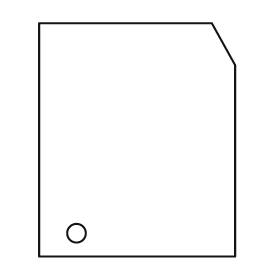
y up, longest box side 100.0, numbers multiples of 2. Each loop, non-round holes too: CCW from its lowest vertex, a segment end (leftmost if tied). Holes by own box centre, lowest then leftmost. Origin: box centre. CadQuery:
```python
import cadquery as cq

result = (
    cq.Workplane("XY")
    .moveTo(-42.0, -50.0)
    .lineTo(42.0, -50.0)
    .lineTo(42.0, 32.0)
    .lineTo(32.0, 50.0)
    .lineTo(-42.0, 50.0)
    .close()
    .moveTo(-26.0, -40.0)
    .circle(4.0)
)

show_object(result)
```